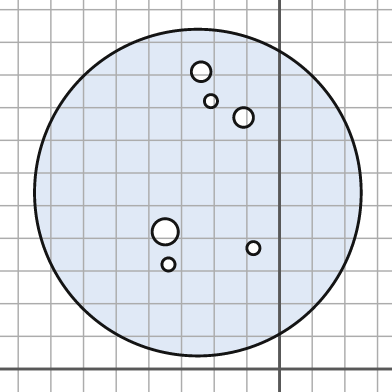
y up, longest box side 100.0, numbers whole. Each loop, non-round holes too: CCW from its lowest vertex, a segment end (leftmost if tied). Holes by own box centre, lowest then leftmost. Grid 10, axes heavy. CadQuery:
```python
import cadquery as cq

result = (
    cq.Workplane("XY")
    .moveTo(-25.0, 54.0)
    .circle(50.0)
    .moveTo(-34.0, 32.0)
    .circle(2.0)
    .moveTo(-8.0, 37.0)
    .circle(2.0)
    .moveTo(-35.0, 42.0)
    .circle(4.0)
    .moveTo(-11.0, 77.0)
    .circle(3.0)
    .moveTo(-21.0, 82.0)
    .circle(2.0)
    .moveTo(-24.0, 91.0)
    .circle(3.0)
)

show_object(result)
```